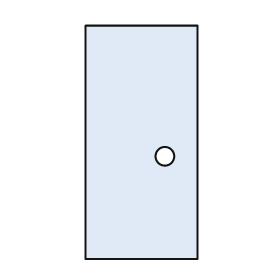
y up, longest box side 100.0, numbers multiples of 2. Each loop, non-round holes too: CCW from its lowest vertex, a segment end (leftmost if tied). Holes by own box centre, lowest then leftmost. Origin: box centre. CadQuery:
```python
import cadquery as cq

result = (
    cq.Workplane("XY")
    .moveTo(-24.0, -50.0)
    .lineTo(24.0, -50.0)
    .lineTo(24.0, 50.0)
    .lineTo(-24.0, 50.0)
    .close()
    .moveTo(10.0, -6.0)
    .circle(4.0)
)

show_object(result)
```